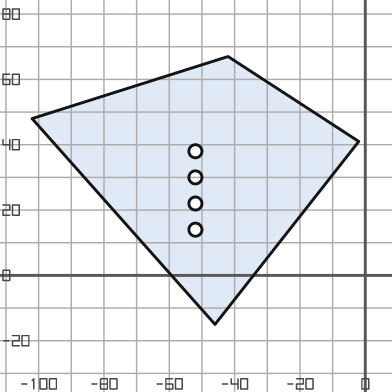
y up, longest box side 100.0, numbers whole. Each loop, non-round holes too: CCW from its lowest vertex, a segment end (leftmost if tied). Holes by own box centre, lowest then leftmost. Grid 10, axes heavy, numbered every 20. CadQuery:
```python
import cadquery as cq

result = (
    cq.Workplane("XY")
    .moveTo(-46.0, -15.0)
    .lineTo(-2.0, 41.0)
    .lineTo(-42.0, 67.0)
    .lineTo(-102.0, 48.0)
    .close()
    .moveTo(-52.0, 14.0)
    .circle(2.0)
    .moveTo(-52.0, 22.0)
    .circle(2.0)
    .moveTo(-52.0, 30.0)
    .circle(2.0)
    .moveTo(-52.0, 38.0)
    .circle(2.0)
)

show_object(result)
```